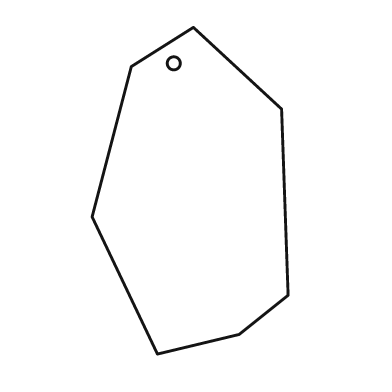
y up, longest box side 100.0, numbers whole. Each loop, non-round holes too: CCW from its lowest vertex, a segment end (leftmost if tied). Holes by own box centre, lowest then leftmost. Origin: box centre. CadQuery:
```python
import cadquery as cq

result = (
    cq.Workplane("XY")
    .moveTo(-10.0, -50.0)
    .lineTo(15.0, -44.0)
    .lineTo(30.0, -32.0)
    .lineTo(28.0, 25.0)
    .lineTo(1.0, 50.0)
    .lineTo(-18.0, 38.0)
    .lineTo(-30.0, -8.0)
    .close()
    .moveTo(-5.0, 39.0)
    .circle(2.0)
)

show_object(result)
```